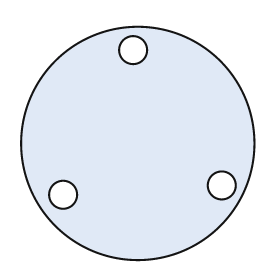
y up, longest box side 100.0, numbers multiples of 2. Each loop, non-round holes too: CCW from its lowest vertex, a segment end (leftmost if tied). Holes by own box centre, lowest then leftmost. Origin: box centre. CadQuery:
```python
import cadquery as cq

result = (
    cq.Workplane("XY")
    .moveTo(0.0, 0.0)
    .circle(50.0)
    .moveTo(-32.0, -22.0)
    .circle(6.0)
    .moveTo(36.0, -18.0)
    .circle(6.0)
    .moveTo(-2.0, 40.0)
    .circle(6.0)
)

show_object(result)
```